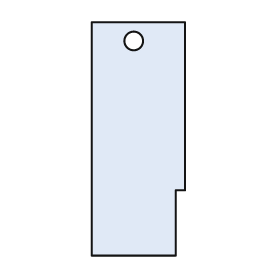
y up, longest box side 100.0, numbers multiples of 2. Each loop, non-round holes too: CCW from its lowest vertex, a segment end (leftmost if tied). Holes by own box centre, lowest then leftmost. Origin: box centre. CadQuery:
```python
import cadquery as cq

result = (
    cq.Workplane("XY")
    .moveTo(-20.0, -50.0)
    .lineTo(16.0, -50.0)
    .lineTo(16.0, -22.0)
    .lineTo(20.0, -22.0)
    .lineTo(20.0, 50.0)
    .lineTo(-20.0, 50.0)
    .close()
    .moveTo(-2.0, 42.0)
    .circle(4.0)
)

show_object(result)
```